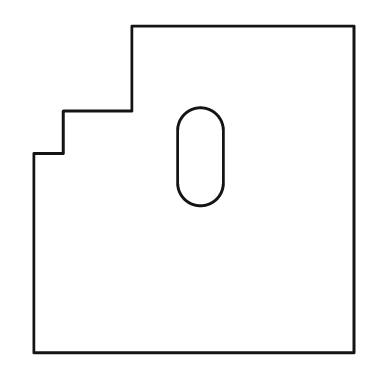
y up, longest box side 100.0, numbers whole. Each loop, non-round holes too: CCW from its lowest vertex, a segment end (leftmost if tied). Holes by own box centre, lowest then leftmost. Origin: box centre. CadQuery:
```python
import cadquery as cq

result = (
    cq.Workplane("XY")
    .moveTo(-49.0, -50.0)
    .lineTo(49.0, -50.0)
    .lineTo(49.0, 50.0)
    .lineTo(-19.0, 50.0)
    .lineTo(-19.0, 24.0)
    .lineTo(-40.0, 24.0)
    .lineTo(-40.0, 11.0)
    .lineTo(-49.0, 11.0)
    .close()
    .moveTo(-5.0, 2.0)
    .threePointArc((2.0, -5.0), (9.0, 2.0))
    .lineTo(9.0, 18.0)
    .threePointArc((2.0, 25.0), (-5.0, 18.0))
    .close()
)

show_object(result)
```